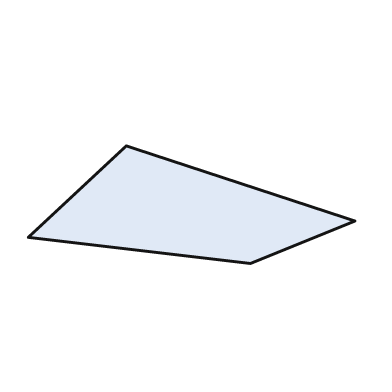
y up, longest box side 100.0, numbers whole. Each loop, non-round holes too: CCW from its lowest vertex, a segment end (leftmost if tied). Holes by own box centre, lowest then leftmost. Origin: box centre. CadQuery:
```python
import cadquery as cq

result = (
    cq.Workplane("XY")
    .moveTo(18.0, -18.0)
    .lineTo(50.0, -5.0)
    .lineTo(-20.0, 18.0)
    .lineTo(-50.0, -10.0)
    .close()
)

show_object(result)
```